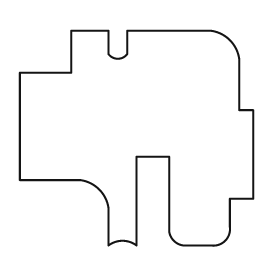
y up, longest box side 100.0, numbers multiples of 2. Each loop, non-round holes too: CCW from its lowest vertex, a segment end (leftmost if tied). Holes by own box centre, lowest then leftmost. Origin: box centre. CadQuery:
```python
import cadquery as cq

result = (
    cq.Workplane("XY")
    .moveTo(-12.0, -46.0)
    .threePointArc((-6.0, -44.0), (0.0, -46.0))
    .lineTo(0.0, -8.0)
    .lineTo(14.0, -8.0)
    .lineTo(14.0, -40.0)
    .threePointArc((16.0, -44.0), (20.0, -46.0))
    .lineTo(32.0, -46.0)
    .threePointArc((38.0, -44.0), (40.0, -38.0))
    .lineTo(40.0, -26.0)
    .lineTo(50.0, -26.0)
    .lineTo(50.0, 12.0)
    .lineTo(44.0, 12.0)
    .lineTo(44.0, 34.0)
    .threePointArc((40.0, 42.0), (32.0, 46.0))
    .lineTo(-4.0, 46.0)
    .lineTo(-4.0, 36.0)
    .threePointArc((-8.0, 34.0), (-12.0, 36.0))
    .lineTo(-12.0, 46.0)
    .lineTo(-28.0, 46.0)
    .lineTo(-28.0, 28.0)
    .lineTo(-50.0, 28.0)
    .lineTo(-50.0, -18.0)
    .lineTo(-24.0, -18.0)
    .threePointArc((-16.0, -22.0), (-12.0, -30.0))
    .close()
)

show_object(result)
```